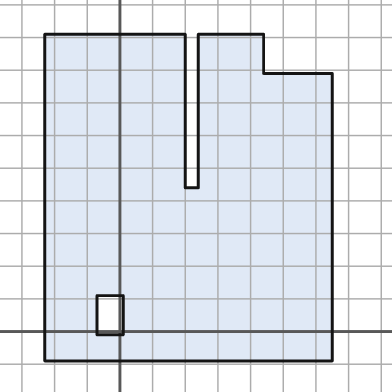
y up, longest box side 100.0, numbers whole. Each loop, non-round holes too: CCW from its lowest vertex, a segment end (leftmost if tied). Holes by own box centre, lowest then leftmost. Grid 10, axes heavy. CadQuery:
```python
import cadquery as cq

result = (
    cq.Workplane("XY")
    .moveTo(-23.0, -9.0)
    .lineTo(65.0, -9.0)
    .lineTo(65.0, 79.0)
    .lineTo(44.0, 79.0)
    .lineTo(44.0, 91.0)
    .lineTo(24.0, 91.0)
    .lineTo(24.0, 44.0)
    .lineTo(20.0, 44.0)
    .lineTo(20.0, 91.0)
    .lineTo(-23.0, 91.0)
    .close()
    .moveTo(-7.0, -1.0)
    .lineTo(1.0, -1.0)
    .lineTo(1.0, 11.0)
    .lineTo(-7.0, 11.0)
    .close()
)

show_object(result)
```